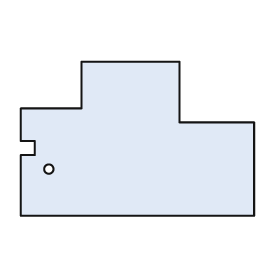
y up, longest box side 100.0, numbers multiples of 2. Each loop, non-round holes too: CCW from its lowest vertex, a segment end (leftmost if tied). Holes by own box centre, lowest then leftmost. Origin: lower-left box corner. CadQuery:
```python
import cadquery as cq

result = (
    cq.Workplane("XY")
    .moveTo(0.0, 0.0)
    .lineTo(100.0, 0.0)
    .lineTo(100.0, 40.0)
    .lineTo(68.0, 40.0)
    .lineTo(68.0, 66.0)
    .lineTo(26.0, 66.0)
    .lineTo(26.0, 46.0)
    .lineTo(0.0, 46.0)
    .lineTo(0.0, 32.0)
    .lineTo(6.0, 32.0)
    .lineTo(6.0, 26.0)
    .lineTo(0.0, 26.0)
    .close()
    .moveTo(12.0, 20.0)
    .circle(2.0)
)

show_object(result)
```